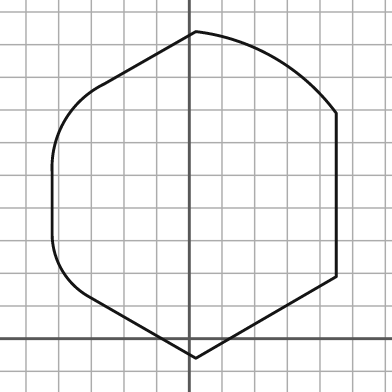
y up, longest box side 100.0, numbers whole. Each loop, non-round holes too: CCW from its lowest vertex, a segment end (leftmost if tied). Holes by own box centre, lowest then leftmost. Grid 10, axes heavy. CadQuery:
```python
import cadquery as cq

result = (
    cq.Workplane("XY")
    .moveTo(2.0, -6.0)
    .lineTo(45.0, 19.0)
    .lineTo(45.0, 69.0)
    .threePointArc((26.0, 86.0), (2.0, 94.0))
    .lineTo(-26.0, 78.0)
    .threePointArc((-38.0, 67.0), (-42.0, 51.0))
    .lineTo(-42.0, 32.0)
    .threePointArc((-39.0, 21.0), (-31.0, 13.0))
    .close()
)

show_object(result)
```